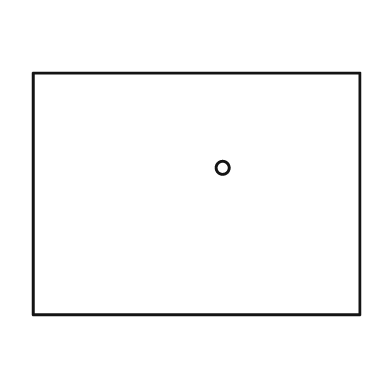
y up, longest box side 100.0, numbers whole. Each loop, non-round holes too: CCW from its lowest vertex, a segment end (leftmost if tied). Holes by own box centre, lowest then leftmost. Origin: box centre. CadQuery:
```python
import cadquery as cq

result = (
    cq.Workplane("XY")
    .moveTo(-50.0, -37.0)
    .lineTo(50.0, -37.0)
    .lineTo(50.0, 37.0)
    .lineTo(-50.0, 37.0)
    .close()
    .moveTo(8.0, 8.0)
    .circle(2.0)
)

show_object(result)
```